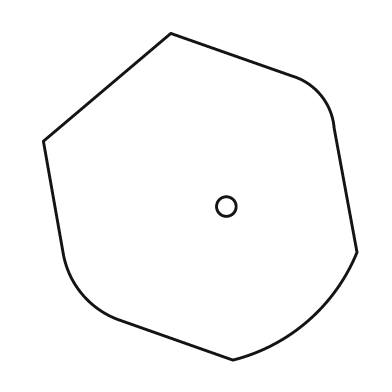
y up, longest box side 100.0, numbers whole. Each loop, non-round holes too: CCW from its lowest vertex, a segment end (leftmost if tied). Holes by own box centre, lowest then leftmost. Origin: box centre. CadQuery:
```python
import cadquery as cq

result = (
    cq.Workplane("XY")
    .moveTo(10.0, -50.0)
    .threePointArc((33.0, -38.0), (48.0, -17.0))
    .lineTo(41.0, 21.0)
    .threePointArc((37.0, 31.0), (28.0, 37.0))
    .lineTo(-9.0, 50.0)
    .lineTo(-48.0, 17.0)
    .lineTo(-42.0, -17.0)
    .threePointArc((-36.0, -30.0), (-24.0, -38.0))
    .close()
    .moveTo(8.0, -3.0)
    .circle(3.0)
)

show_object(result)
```